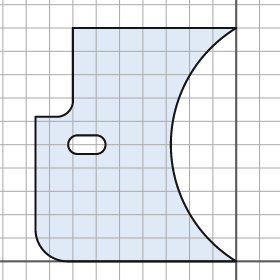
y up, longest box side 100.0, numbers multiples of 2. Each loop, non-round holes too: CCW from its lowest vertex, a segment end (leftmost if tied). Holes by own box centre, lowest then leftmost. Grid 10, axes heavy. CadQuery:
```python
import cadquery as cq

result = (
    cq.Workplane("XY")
    .moveTo(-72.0, 0.0)
    .lineTo(0.0, 0.0)
    .threePointArc((-28.0, 50.0), (0.0, 100.0))
    .lineTo(-70.0, 100.0)
    .lineTo(-70.0, 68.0)
    .threePointArc((-72.0, 64.0), (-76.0, 62.0))
    .lineTo(-86.0, 62.0)
    .lineTo(-86.0, 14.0)
    .threePointArc((-82.0, 4.0), (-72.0, 0.0))
    .close()
    .moveTo(-68.0, 46.0)
    .lineTo(-60.0, 46.0)
    .threePointArc((-56.0, 50.0), (-60.0, 54.0))
    .lineTo(-68.0, 54.0)
    .threePointArc((-72.0, 50.0), (-68.0, 46.0))
    .close()
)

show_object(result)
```